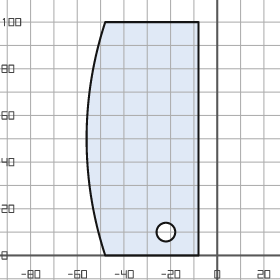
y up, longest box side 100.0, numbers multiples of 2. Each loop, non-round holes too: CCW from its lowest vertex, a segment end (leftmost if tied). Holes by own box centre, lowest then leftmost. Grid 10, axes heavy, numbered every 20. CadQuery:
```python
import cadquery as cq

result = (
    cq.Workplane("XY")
    .moveTo(-48.0, 0.0)
    .lineTo(-8.0, 0.0)
    .lineTo(-8.0, 100.0)
    .lineTo(-48.0, 100.0)
    .threePointArc((-56.0, 50.0), (-48.0, 0.0))
    .close()
    .moveTo(-22.0, 10.0)
    .circle(4.0)
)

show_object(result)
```